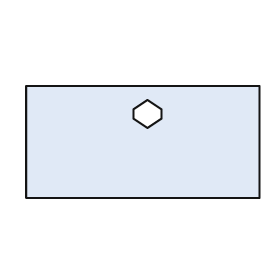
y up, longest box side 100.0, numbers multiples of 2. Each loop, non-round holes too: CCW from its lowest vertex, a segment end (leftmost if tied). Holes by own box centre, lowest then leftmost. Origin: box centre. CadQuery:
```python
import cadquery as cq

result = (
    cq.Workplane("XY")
    .moveTo(-50.0, -24.0)
    .lineTo(50.0, -24.0)
    .lineTo(50.0, 24.0)
    .lineTo(-50.0, 24.0)
    .close()
    .moveTo(2.0, 6.0)
    .lineTo(8.0, 10.0)
    .lineTo(8.0, 14.0)
    .lineTo(2.0, 18.0)
    .lineTo(-4.0, 14.0)
    .lineTo(-4.0, 10.0)
    .close()
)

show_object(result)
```